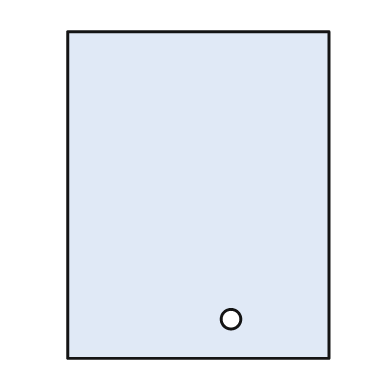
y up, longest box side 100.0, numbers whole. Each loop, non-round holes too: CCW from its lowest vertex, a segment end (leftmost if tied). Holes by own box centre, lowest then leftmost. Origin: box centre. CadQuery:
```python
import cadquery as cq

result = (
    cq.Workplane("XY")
    .moveTo(-40.0, -50.0)
    .lineTo(40.0, -50.0)
    .lineTo(40.0, 50.0)
    .lineTo(-40.0, 50.0)
    .close()
    .moveTo(10.0, -38.0)
    .circle(3.0)
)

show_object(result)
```